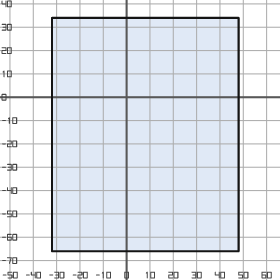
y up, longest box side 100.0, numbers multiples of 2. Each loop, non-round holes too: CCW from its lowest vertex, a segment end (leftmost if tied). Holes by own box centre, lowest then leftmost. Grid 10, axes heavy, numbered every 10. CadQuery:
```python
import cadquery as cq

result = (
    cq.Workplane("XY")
    .moveTo(-32.0, -66.0)
    .lineTo(48.0, -66.0)
    .lineTo(48.0, 34.0)
    .lineTo(-32.0, 34.0)
    .close()
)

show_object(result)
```